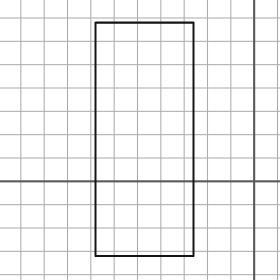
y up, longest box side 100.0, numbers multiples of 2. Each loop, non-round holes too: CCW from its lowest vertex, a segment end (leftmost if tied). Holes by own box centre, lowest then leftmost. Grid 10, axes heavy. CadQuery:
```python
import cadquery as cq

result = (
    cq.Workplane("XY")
    .moveTo(-68.0, -32.0)
    .lineTo(-26.0, -32.0)
    .lineTo(-26.0, 68.0)
    .lineTo(-68.0, 68.0)
    .close()
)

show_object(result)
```